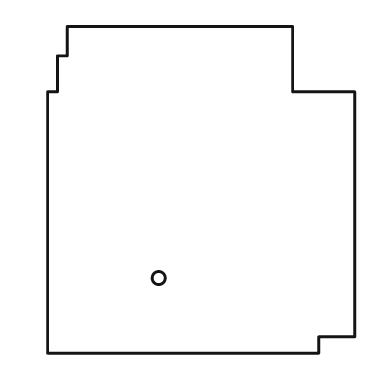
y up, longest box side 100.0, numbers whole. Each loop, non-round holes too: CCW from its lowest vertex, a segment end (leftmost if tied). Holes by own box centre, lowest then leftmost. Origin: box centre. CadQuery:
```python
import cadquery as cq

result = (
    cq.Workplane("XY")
    .moveTo(-47.0, -50.0)
    .lineTo(36.0, -50.0)
    .lineTo(36.0, -45.0)
    .lineTo(47.0, -45.0)
    .lineTo(47.0, 30.0)
    .lineTo(28.0, 30.0)
    .lineTo(28.0, 50.0)
    .lineTo(-41.0, 50.0)
    .lineTo(-41.0, 41.0)
    .lineTo(-44.0, 41.0)
    .lineTo(-44.0, 30.0)
    .lineTo(-47.0, 30.0)
    .close()
    .moveTo(-13.0, -27.0)
    .circle(2.0)
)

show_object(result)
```